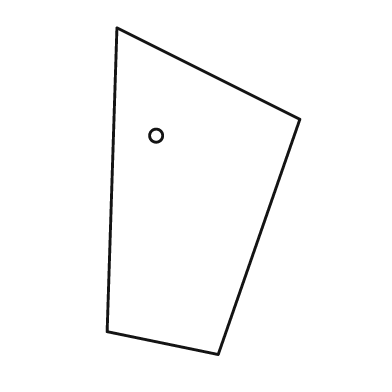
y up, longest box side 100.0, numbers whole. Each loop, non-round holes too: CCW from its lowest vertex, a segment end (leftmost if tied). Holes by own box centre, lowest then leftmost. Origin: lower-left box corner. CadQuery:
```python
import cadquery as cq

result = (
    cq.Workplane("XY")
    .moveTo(34.0, 0.0)
    .lineTo(59.0, 72.0)
    .lineTo(3.0, 100.0)
    .lineTo(0.0, 7.0)
    .close()
    .moveTo(15.0, 67.0)
    .circle(2.0)
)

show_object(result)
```